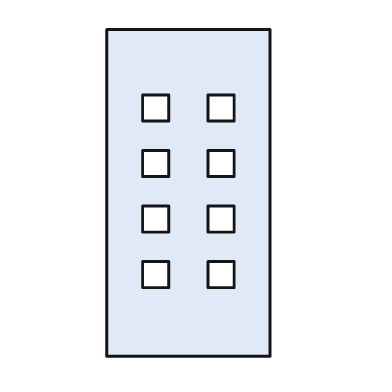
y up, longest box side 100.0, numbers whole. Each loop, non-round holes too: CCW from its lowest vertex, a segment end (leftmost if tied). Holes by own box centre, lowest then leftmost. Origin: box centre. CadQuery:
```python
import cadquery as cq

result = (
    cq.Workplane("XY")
    .moveTo(-25.0, -50.0)
    .lineTo(25.0, -50.0)
    .lineTo(25.0, 50.0)
    .lineTo(-25.0, 50.0)
    .close()
    .moveTo(-14.0, -29.0)
    .lineTo(-6.0, -29.0)
    .lineTo(-6.0, -21.0)
    .lineTo(-14.0, -21.0)
    .close()
    .moveTo(6.0, -29.0)
    .lineTo(14.0, -29.0)
    .lineTo(14.0, -21.0)
    .lineTo(6.0, -21.0)
    .close()
    .moveTo(-14.0, -12.0)
    .lineTo(-6.0, -12.0)
    .lineTo(-6.0, -4.0)
    .lineTo(-14.0, -4.0)
    .close()
    .moveTo(6.0, -12.0)
    .lineTo(14.0, -12.0)
    .lineTo(14.0, -4.0)
    .lineTo(6.0, -4.0)
    .close()
    .moveTo(-14.0, 5.0)
    .lineTo(-6.0, 5.0)
    .lineTo(-6.0, 13.0)
    .lineTo(-14.0, 13.0)
    .close()
    .moveTo(6.0, 5.0)
    .lineTo(14.0, 5.0)
    .lineTo(14.0, 13.0)
    .lineTo(6.0, 13.0)
    .close()
    .moveTo(-14.0, 22.0)
    .lineTo(-6.0, 22.0)
    .lineTo(-6.0, 30.0)
    .lineTo(-14.0, 30.0)
    .close()
    .moveTo(6.0, 22.0)
    .lineTo(14.0, 22.0)
    .lineTo(14.0, 30.0)
    .lineTo(6.0, 30.0)
    .close()
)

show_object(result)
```